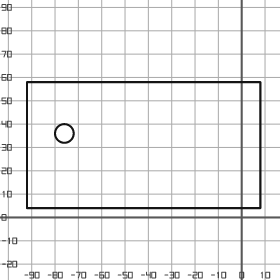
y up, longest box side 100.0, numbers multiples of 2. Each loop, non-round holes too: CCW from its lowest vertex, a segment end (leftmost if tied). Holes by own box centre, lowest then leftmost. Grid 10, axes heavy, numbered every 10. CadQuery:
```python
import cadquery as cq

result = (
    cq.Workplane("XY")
    .moveTo(-92.0, 4.0)
    .lineTo(8.0, 4.0)
    .lineTo(8.0, 58.0)
    .lineTo(-92.0, 58.0)
    .close()
    .moveTo(-76.0, 36.0)
    .circle(4.0)
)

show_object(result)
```